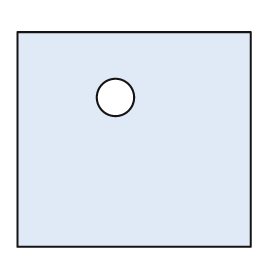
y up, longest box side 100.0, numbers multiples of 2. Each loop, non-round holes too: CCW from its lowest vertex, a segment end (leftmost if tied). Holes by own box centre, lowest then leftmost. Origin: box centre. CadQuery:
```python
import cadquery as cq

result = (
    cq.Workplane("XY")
    .moveTo(-50.0, -46.0)
    .lineTo(50.0, -46.0)
    .lineTo(50.0, 46.0)
    .lineTo(-50.0, 46.0)
    .close()
    .moveTo(-8.0, 18.0)
    .circle(8.0)
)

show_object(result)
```